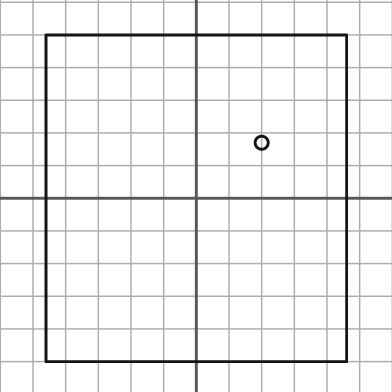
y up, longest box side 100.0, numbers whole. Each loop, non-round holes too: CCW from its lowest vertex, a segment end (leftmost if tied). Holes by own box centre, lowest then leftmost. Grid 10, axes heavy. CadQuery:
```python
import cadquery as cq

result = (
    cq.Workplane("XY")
    .moveTo(-46.0, -50.0)
    .lineTo(46.0, -50.0)
    .lineTo(46.0, 50.0)
    .lineTo(-46.0, 50.0)
    .close()
    .moveTo(20.0, 17.0)
    .circle(2.0)
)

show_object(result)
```